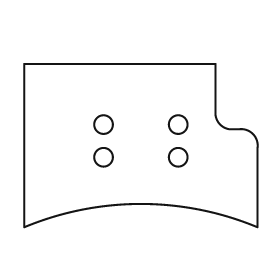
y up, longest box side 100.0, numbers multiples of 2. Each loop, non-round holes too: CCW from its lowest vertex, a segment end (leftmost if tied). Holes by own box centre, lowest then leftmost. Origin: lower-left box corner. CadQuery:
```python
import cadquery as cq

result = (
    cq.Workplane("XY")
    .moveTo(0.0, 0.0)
    .threePointArc((50.0, 10.0), (100.0, 0.0))
    .lineTo(100.0, 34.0)
    .threePointArc((98.0, 40.0), (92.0, 42.0))
    .lineTo(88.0, 42.0)
    .threePointArc((84.0, 44.0), (82.0, 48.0))
    .lineTo(82.0, 70.0)
    .lineTo(0.0, 70.0)
    .close()
    .moveTo(34.0, 30.0)
    .circle(4.0)
    .moveTo(66.0, 30.0)
    .circle(4.0)
    .moveTo(34.0, 44.0)
    .circle(4.0)
    .moveTo(66.0, 44.0)
    .circle(4.0)
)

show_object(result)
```